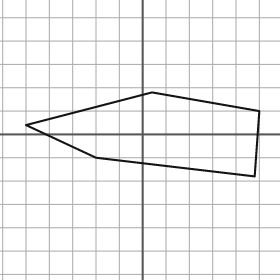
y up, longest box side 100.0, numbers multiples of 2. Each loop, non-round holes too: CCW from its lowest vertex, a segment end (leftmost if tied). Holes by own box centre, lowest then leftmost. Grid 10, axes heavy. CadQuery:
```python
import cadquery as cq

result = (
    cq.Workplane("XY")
    .moveTo(48.0, -18.0)
    .lineTo(50.0, 10.0)
    .lineTo(4.0, 18.0)
    .lineTo(-50.0, 4.0)
    .lineTo(-20.0, -10.0)
    .close()
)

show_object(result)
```